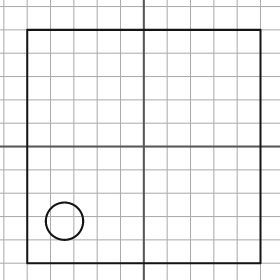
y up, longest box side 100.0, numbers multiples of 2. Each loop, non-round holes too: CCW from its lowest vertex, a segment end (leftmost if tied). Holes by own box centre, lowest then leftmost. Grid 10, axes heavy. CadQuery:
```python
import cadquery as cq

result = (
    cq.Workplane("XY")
    .moveTo(-50.0, -50.0)
    .lineTo(50.0, -50.0)
    .lineTo(50.0, 50.0)
    .lineTo(-50.0, 50.0)
    .close()
    .moveTo(-34.0, -32.0)
    .circle(8.0)
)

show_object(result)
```